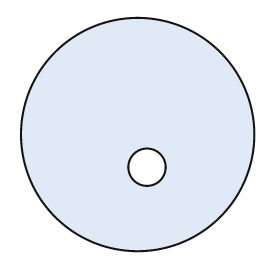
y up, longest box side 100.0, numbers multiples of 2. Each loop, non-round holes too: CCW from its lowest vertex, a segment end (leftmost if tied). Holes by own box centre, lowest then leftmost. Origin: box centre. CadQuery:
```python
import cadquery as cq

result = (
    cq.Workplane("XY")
    .moveTo(0.0, 0.0)
    .circle(50.0)
    .moveTo(4.0, -14.0)
    .circle(8.0)
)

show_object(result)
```